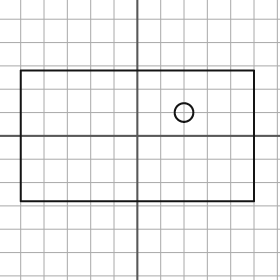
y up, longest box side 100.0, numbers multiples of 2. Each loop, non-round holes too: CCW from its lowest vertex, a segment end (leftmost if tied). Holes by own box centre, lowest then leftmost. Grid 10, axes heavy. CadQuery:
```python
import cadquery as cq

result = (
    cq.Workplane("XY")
    .moveTo(-50.0, -28.0)
    .lineTo(50.0, -28.0)
    .lineTo(50.0, 28.0)
    .lineTo(-50.0, 28.0)
    .close()
    .moveTo(20.0, 10.0)
    .circle(4.0)
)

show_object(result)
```